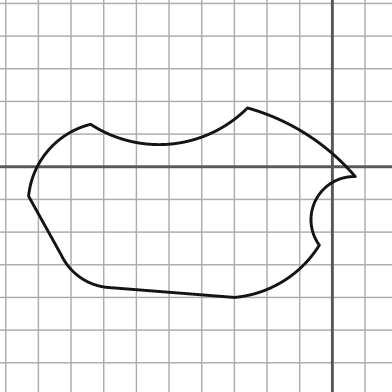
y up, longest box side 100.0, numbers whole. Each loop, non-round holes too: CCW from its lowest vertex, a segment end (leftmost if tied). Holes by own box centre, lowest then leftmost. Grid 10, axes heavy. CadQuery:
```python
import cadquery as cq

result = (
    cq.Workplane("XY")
    .moveTo(-30.0, -40.0)
    .threePointArc((-15.0, -35.0), (-4.0, -24.0))
    .threePointArc((-5.0, -10.0), (7.0, -3.0))
    .threePointArc((-8.0, 10.0), (-26.0, 18.0))
    .threePointArc((-49.0, 7.0), (-74.0, 13.0))
    .threePointArc((-87.0, 5.0), (-93.0, -9.0))
    .lineTo(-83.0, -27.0)
    .threePointArc((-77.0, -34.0), (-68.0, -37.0))
    .close()
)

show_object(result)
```